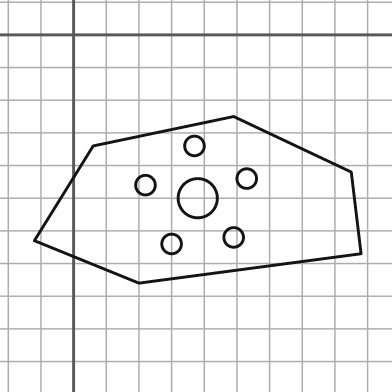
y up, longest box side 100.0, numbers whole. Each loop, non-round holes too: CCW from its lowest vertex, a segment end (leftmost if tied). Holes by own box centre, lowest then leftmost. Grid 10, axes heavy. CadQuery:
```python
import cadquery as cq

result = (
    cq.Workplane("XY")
    .moveTo(20.0, -76.0)
    .lineTo(88.0, -67.0)
    .lineTo(85.0, -42.0)
    .lineTo(49.0, -25.0)
    .lineTo(6.0, -34.0)
    .lineTo(-12.0, -63.0)
    .close()
    .moveTo(30.0, -64.0)
    .circle(3.0)
    .moveTo(49.0, -62.0)
    .circle(3.0)
    .moveTo(38.0, -50.0)
    .circle(6.0)
    .moveTo(22.0, -46.0)
    .circle(3.0)
    .moveTo(53.0, -44.0)
    .circle(3.0)
    .moveTo(37.0, -34.0)
    .circle(3.0)
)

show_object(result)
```